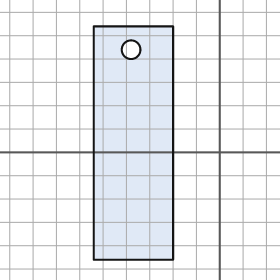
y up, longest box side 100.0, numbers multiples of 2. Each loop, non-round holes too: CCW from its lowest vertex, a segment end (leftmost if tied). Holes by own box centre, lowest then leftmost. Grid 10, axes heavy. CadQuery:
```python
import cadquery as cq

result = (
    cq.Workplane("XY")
    .moveTo(-54.0, -46.0)
    .lineTo(-20.0, -46.0)
    .lineTo(-20.0, 54.0)
    .lineTo(-54.0, 54.0)
    .close()
    .moveTo(-38.0, 44.0)
    .circle(4.0)
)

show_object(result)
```